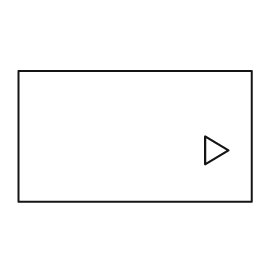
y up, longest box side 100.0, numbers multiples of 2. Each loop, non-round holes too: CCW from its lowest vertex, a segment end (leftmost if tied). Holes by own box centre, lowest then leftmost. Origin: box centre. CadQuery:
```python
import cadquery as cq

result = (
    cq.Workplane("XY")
    .moveTo(-50.0, -28.0)
    .lineTo(50.0, -28.0)
    .lineTo(50.0, 28.0)
    .lineTo(-50.0, 28.0)
    .close()
    .moveTo(30.0, -12.0)
    .lineTo(40.0, -6.0)
    .lineTo(30.0, 0.0)
    .close()
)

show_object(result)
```